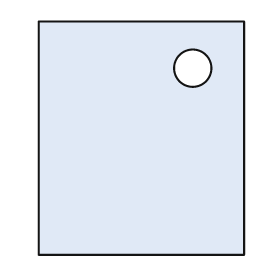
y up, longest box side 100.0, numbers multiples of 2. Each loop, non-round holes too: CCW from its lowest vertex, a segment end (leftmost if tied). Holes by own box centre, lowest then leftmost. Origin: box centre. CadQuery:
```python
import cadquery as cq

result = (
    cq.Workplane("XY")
    .moveTo(-44.0, -50.0)
    .lineTo(44.0, -50.0)
    .lineTo(44.0, 50.0)
    .lineTo(-44.0, 50.0)
    .close()
    .moveTo(22.0, 30.0)
    .circle(8.0)
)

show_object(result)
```